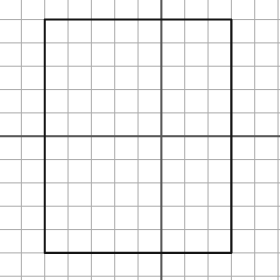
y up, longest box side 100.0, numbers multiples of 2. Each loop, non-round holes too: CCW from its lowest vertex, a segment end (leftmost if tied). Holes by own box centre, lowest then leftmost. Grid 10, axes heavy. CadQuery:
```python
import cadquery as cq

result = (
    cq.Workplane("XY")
    .moveTo(-50.0, -50.0)
    .lineTo(30.0, -50.0)
    .lineTo(30.0, 50.0)
    .lineTo(-50.0, 50.0)
    .close()
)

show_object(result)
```